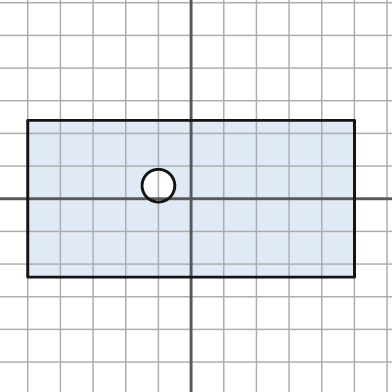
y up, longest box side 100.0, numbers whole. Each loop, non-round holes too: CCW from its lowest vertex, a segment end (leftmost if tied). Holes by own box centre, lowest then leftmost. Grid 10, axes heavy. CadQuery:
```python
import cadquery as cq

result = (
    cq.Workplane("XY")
    .moveTo(-50.0, -24.0)
    .lineTo(50.0, -24.0)
    .lineTo(50.0, 24.0)
    .lineTo(-50.0, 24.0)
    .close()
    .moveTo(-10.0, 4.0)
    .circle(5.0)
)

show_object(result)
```